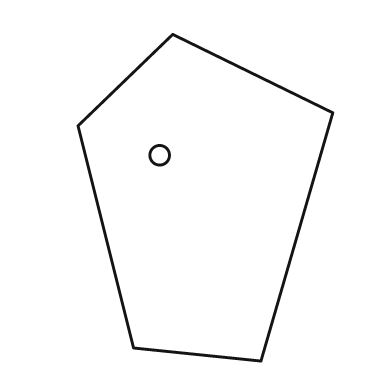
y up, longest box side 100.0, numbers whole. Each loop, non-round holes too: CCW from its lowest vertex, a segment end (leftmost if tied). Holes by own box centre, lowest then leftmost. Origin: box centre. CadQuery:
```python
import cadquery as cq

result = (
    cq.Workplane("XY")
    .moveTo(17.0, -50.0)
    .lineTo(39.0, 26.0)
    .lineTo(-10.0, 50.0)
    .lineTo(-39.0, 22.0)
    .lineTo(-22.0, -46.0)
    .close()
    .moveTo(-14.0, 13.0)
    .circle(3.0)
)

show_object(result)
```